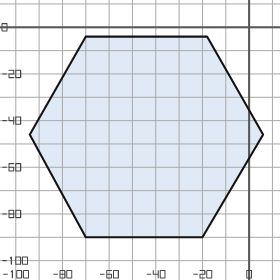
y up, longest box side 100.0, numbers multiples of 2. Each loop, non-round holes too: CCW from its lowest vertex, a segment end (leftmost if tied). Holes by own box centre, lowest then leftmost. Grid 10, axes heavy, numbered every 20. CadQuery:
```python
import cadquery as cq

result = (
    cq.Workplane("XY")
    .moveTo(-70.0, -90.0)
    .lineTo(-20.0, -90.0)
    .lineTo(6.0, -46.0)
    .lineTo(-18.0, -4.0)
    .lineTo(-70.0, -4.0)
    .lineTo(-94.0, -46.0)
    .close()
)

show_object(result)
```